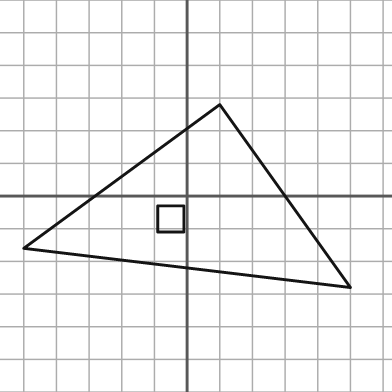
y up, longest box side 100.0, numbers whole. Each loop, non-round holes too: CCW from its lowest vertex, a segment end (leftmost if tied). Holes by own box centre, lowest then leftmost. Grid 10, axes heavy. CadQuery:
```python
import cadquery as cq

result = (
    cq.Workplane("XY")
    .moveTo(50.0, -28.0)
    .lineTo(10.0, 28.0)
    .lineTo(-50.0, -16.0)
    .close()
    .moveTo(-9.0, -11.0)
    .lineTo(-1.0, -11.0)
    .lineTo(-1.0, -3.0)
    .lineTo(-9.0, -3.0)
    .close()
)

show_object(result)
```